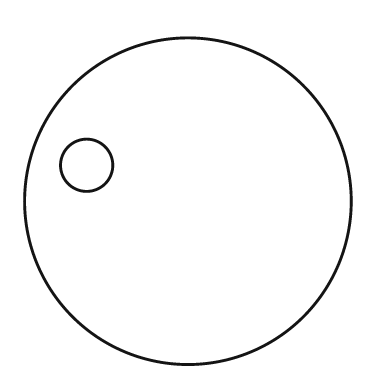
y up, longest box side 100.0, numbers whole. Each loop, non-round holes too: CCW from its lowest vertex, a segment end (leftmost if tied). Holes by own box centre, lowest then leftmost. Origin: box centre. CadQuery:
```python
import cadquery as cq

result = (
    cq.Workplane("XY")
    .moveTo(0.0, 0.0)
    .circle(50.0)
    .moveTo(-31.0, 11.0)
    .circle(8.0)
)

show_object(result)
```